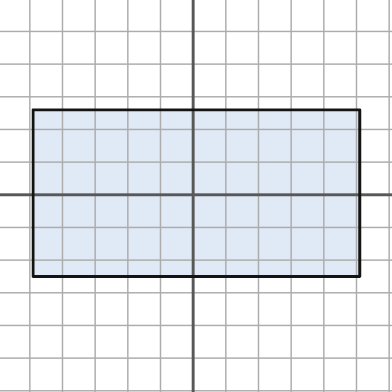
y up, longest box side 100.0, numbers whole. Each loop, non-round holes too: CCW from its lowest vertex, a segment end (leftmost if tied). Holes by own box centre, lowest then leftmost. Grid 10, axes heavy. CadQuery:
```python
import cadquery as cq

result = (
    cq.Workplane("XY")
    .moveTo(-49.0, -25.0)
    .lineTo(51.0, -25.0)
    .lineTo(51.0, 26.0)
    .lineTo(-49.0, 26.0)
    .close()
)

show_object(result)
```